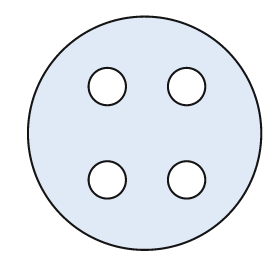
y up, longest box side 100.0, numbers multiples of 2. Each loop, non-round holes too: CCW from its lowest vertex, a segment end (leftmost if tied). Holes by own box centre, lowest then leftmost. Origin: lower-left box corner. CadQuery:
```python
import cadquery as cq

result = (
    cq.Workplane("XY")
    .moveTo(50.0, 50.0)
    .circle(50.0)
    .moveTo(34.0, 30.0)
    .circle(8.0)
    .moveTo(68.0, 30.0)
    .circle(8.0)
    .moveTo(34.0, 70.0)
    .circle(8.0)
    .moveTo(68.0, 70.0)
    .circle(8.0)
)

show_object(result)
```